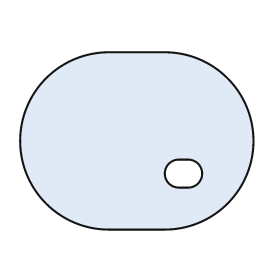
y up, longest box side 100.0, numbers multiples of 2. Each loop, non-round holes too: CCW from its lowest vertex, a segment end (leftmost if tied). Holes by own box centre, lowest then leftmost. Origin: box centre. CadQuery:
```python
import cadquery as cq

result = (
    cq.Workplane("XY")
    .moveTo(-12.0, -38.0)
    .lineTo(12.0, -38.0)
    .threePointArc((50.0, 0.0), (12.0, 38.0))
    .lineTo(-12.0, 38.0)
    .threePointArc((-50.0, 0.0), (-12.0, -38.0))
    .close()
    .moveTo(18.0, -20.0)
    .lineTo(22.0, -20.0)
    .threePointArc((28.0, -14.0), (22.0, -8.0))
    .lineTo(18.0, -8.0)
    .threePointArc((12.0, -14.0), (18.0, -20.0))
    .close()
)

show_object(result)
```